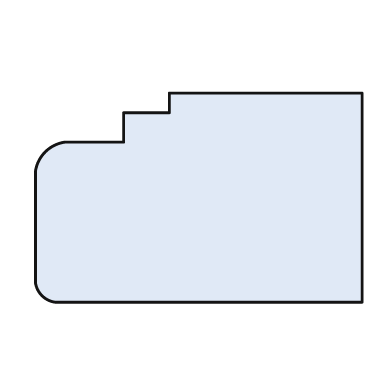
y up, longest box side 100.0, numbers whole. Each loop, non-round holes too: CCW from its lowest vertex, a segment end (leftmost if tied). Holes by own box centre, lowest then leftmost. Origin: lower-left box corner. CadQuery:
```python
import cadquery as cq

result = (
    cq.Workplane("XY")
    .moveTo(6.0, 0.0)
    .lineTo(100.0, 0.0)
    .lineTo(100.0, 64.0)
    .lineTo(41.0, 64.0)
    .lineTo(41.0, 58.0)
    .lineTo(27.0, 58.0)
    .lineTo(27.0, 49.0)
    .lineTo(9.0, 49.0)
    .threePointArc((3.0, 46.0), (0.0, 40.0))
    .lineTo(0.0, 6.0)
    .threePointArc((2.0, 2.0), (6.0, 0.0))
    .close()
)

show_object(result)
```